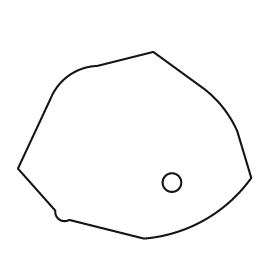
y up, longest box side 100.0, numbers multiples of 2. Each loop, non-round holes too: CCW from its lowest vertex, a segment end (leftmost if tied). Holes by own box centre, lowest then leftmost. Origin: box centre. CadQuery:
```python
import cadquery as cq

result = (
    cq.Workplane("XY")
    .moveTo(4.0, -40.0)
    .threePointArc((30.0, -32.0), (50.0, -14.0))
    .lineTo(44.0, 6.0)
    .threePointArc((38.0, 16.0), (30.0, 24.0))
    .lineTo(8.0, 40.0)
    .lineTo(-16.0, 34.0)
    .threePointArc((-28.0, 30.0), (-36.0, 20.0))
    .lineTo(-50.0, -10.0)
    .lineTo(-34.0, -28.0)
    .threePointArc((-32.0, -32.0), (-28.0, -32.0))
    .close()
    .moveTo(16.0, -16.0)
    .circle(4.0)
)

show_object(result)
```